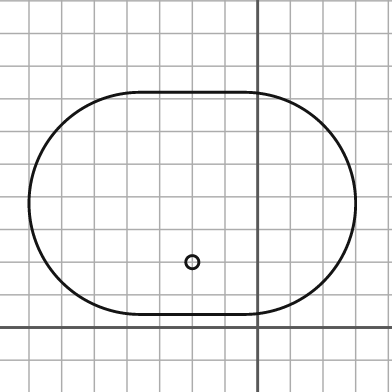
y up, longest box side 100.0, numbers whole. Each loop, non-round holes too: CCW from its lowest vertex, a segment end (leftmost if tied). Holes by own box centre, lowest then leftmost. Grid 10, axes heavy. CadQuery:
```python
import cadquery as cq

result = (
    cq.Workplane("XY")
    .moveTo(-36.0, 4.0)
    .lineTo(-4.0, 4.0)
    .threePointArc((30.0, 38.0), (-4.0, 72.0))
    .lineTo(-36.0, 72.0)
    .threePointArc((-70.0, 38.0), (-36.0, 4.0))
    .close()
    .moveTo(-20.0, 20.0)
    .circle(2.0)
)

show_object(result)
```